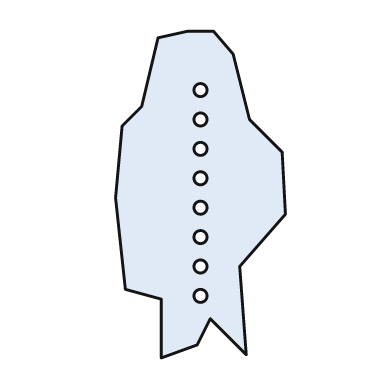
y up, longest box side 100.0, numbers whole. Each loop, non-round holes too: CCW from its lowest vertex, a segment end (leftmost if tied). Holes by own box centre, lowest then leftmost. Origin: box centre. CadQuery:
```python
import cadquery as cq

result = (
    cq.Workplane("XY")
    .moveTo(-12.0, -50.0)
    .lineTo(-1.0, -46.0)
    .lineTo(3.0, -38.0)
    .lineTo(14.0, -49.0)
    .lineTo(12.0, -22.0)
    .lineTo(26.0, -6.0)
    .lineTo(25.0, 13.0)
    .lineTo(15.0, 23.0)
    .lineTo(10.0, 43.0)
    .lineTo(4.0, 50.0)
    .lineTo(-4.0, 50.0)
    .lineTo(-13.0, 48.0)
    .lineTo(-18.0, 27.0)
    .lineTo(-24.0, 21.0)
    .lineTo(-26.0, -1.0)
    .lineTo(-23.0, -29.0)
    .lineTo(-12.0, -32.0)
    .close()
    .moveTo(0.0, -31.0)
    .circle(2.0)
    .moveTo(0.0, -22.0)
    .circle(2.0)
    .moveTo(0.0, -13.0)
    .circle(2.0)
    .moveTo(0.0, -4.0)
    .circle(2.0)
    .moveTo(0.0, 5.0)
    .circle(2.0)
    .moveTo(0.0, 14.0)
    .circle(2.0)
    .moveTo(0.0, 23.0)
    .circle(2.0)
    .moveTo(0.0, 32.0)
    .circle(2.0)
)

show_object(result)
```